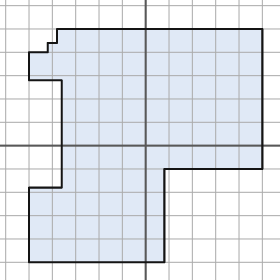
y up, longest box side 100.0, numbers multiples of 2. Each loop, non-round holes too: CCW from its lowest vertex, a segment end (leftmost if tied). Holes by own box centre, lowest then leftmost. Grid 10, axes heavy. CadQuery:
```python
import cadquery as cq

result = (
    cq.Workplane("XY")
    .moveTo(-50.0, -50.0)
    .lineTo(8.0, -50.0)
    .lineTo(8.0, -10.0)
    .lineTo(50.0, -10.0)
    .lineTo(50.0, 50.0)
    .lineTo(-38.0, 50.0)
    .lineTo(-38.0, 44.0)
    .lineTo(-42.0, 44.0)
    .lineTo(-42.0, 40.0)
    .lineTo(-50.0, 40.0)
    .lineTo(-50.0, 28.0)
    .lineTo(-36.0, 28.0)
    .lineTo(-36.0, -18.0)
    .lineTo(-50.0, -18.0)
    .close()
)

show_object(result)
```